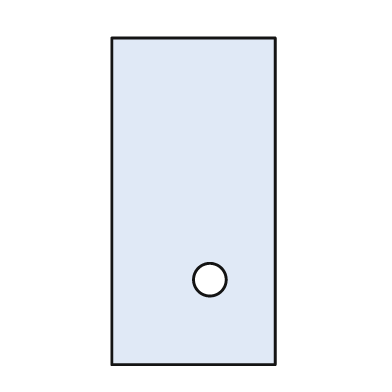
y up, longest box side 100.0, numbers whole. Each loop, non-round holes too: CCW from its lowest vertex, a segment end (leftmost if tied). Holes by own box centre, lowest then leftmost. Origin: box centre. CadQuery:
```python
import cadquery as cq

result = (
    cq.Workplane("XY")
    .moveTo(-25.0, -50.0)
    .lineTo(25.0, -50.0)
    .lineTo(25.0, 50.0)
    .lineTo(-25.0, 50.0)
    .close()
    .moveTo(5.0, -24.0)
    .circle(5.0)
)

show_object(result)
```